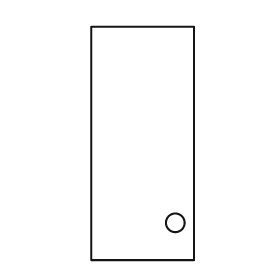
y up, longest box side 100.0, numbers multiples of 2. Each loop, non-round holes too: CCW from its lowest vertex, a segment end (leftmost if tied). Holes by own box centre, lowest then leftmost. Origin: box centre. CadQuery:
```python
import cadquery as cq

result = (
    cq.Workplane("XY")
    .moveTo(-22.0, -50.0)
    .lineTo(22.0, -50.0)
    .lineTo(22.0, 50.0)
    .lineTo(-22.0, 50.0)
    .close()
    .moveTo(14.0, -34.0)
    .circle(4.0)
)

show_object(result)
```